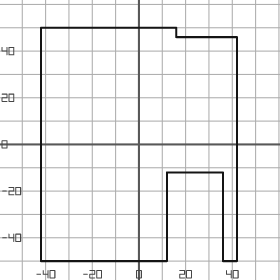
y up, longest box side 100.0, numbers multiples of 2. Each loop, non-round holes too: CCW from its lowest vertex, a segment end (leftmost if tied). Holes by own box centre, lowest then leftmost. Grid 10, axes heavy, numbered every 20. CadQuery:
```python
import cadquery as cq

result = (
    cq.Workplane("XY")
    .moveTo(-42.0, -50.0)
    .lineTo(12.0, -50.0)
    .lineTo(12.0, -12.0)
    .lineTo(36.0, -12.0)
    .lineTo(36.0, -50.0)
    .lineTo(42.0, -50.0)
    .lineTo(42.0, 46.0)
    .lineTo(16.0, 46.0)
    .lineTo(16.0, 50.0)
    .lineTo(-42.0, 50.0)
    .close()
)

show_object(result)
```